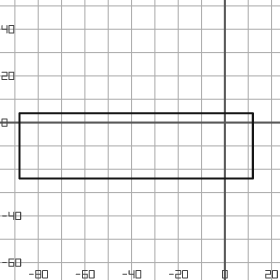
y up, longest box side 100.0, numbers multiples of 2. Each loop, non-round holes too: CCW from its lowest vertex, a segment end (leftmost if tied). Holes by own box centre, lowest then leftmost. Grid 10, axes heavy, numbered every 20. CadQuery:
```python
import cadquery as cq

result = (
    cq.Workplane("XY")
    .moveTo(-88.0, -24.0)
    .lineTo(12.0, -24.0)
    .lineTo(12.0, 4.0)
    .lineTo(-88.0, 4.0)
    .close()
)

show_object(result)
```